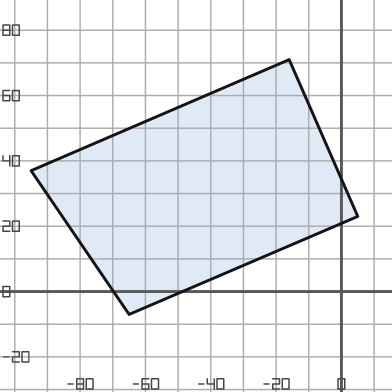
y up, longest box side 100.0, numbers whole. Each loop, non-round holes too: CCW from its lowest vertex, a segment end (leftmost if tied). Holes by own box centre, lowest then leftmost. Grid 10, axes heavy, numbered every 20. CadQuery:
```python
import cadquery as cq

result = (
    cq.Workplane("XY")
    .moveTo(-65.0, -7.0)
    .lineTo(5.0, 23.0)
    .lineTo(-16.0, 71.0)
    .lineTo(-95.0, 37.0)
    .close()
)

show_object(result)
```